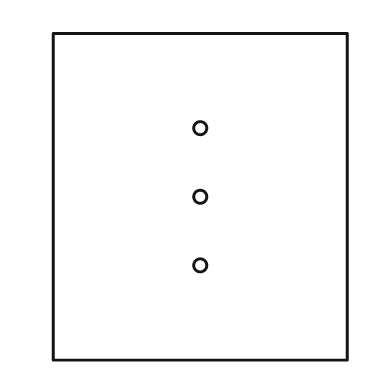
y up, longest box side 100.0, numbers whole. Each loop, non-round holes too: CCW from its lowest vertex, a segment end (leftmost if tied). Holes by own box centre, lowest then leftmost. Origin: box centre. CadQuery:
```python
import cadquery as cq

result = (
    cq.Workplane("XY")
    .moveTo(-45.0, -50.0)
    .lineTo(45.0, -50.0)
    .lineTo(45.0, 50.0)
    .lineTo(-45.0, 50.0)
    .close()
    .moveTo(0.0, -21.0)
    .circle(2.0)
    .moveTo(0.0, 0.0)
    .circle(2.0)
    .moveTo(0.0, 21.0)
    .circle(2.0)
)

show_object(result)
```